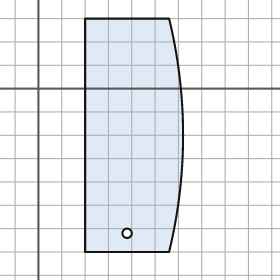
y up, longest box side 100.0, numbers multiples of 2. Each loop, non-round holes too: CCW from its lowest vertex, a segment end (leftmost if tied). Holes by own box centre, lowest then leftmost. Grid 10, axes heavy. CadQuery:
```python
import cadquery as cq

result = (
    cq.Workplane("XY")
    .moveTo(20.0, -70.0)
    .lineTo(56.0, -70.0)
    .threePointArc((62.0, -20.0), (56.0, 30.0))
    .lineTo(20.0, 30.0)
    .close()
    .moveTo(38.0, -62.0)
    .circle(2.0)
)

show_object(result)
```